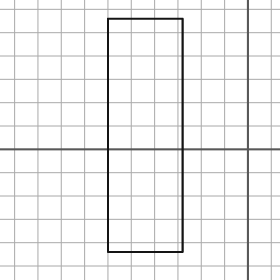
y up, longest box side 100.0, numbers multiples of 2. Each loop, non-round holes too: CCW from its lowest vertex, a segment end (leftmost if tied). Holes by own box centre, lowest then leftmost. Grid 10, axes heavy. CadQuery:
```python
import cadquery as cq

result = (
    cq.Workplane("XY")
    .moveTo(-60.0, -44.0)
    .lineTo(-28.0, -44.0)
    .lineTo(-28.0, 56.0)
    .lineTo(-60.0, 56.0)
    .close()
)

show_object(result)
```